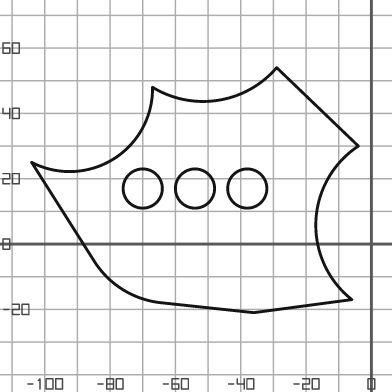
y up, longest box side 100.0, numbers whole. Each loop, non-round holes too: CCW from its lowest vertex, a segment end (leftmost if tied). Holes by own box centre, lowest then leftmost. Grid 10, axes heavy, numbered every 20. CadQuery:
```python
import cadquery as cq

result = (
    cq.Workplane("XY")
    .moveTo(-36.0, -21.0)
    .lineTo(-6.0, -17.0)
    .threePointArc((-17.0, 7.0), (-4.0, 30.0))
    .lineTo(-29.0, 54.0)
    .threePointArc((-47.0, 44.0), (-67.0, 48.0))
    .threePointArc((-79.0, 26.0), (-104.0, 25.0))
    .lineTo(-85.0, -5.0)
    .threePointArc((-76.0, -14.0), (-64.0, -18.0))
    .close()
    .moveTo(-70.0, 17.0)
    .circle(6.0)
    .moveTo(-54.0, 17.0)
    .circle(6.0)
    .moveTo(-38.0, 17.0)
    .circle(6.0)
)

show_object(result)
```